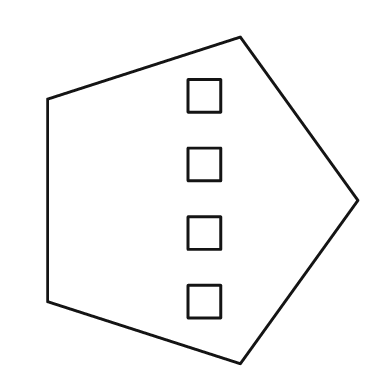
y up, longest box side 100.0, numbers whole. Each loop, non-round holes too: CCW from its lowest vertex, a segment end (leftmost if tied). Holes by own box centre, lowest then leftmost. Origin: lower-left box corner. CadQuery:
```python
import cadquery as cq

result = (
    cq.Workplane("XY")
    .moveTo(59.0, 0.0)
    .lineTo(95.0, 50.0)
    .lineTo(59.0, 100.0)
    .lineTo(0.0, 81.0)
    .lineTo(0.0, 19.0)
    .close()
    .moveTo(43.0, 14.0)
    .lineTo(53.0, 14.0)
    .lineTo(53.0, 24.0)
    .lineTo(43.0, 24.0)
    .close()
    .moveTo(43.0, 35.0)
    .lineTo(53.0, 35.0)
    .lineTo(53.0, 45.0)
    .lineTo(43.0, 45.0)
    .close()
    .moveTo(43.0, 56.0)
    .lineTo(53.0, 56.0)
    .lineTo(53.0, 66.0)
    .lineTo(43.0, 66.0)
    .close()
    .moveTo(43.0, 77.0)
    .lineTo(53.0, 77.0)
    .lineTo(53.0, 87.0)
    .lineTo(43.0, 87.0)
    .close()
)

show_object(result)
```